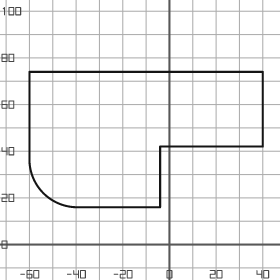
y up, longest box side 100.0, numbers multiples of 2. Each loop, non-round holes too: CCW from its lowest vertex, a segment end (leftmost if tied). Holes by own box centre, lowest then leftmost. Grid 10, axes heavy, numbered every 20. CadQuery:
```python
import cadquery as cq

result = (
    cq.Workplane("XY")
    .moveTo(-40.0, 16.0)
    .lineTo(-4.0, 16.0)
    .lineTo(-4.0, 42.0)
    .lineTo(40.0, 42.0)
    .lineTo(40.0, 74.0)
    .lineTo(-60.0, 74.0)
    .lineTo(-60.0, 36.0)
    .threePointArc((-54.0, 22.0), (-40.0, 16.0))
    .close()
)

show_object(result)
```